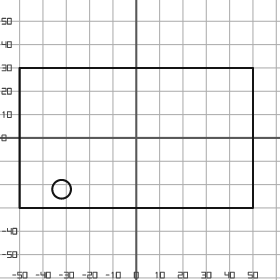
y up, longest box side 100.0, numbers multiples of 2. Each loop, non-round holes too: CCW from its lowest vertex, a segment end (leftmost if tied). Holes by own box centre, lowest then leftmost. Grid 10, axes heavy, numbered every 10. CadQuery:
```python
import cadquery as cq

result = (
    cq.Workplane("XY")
    .moveTo(-50.0, -30.0)
    .lineTo(50.0, -30.0)
    .lineTo(50.0, 30.0)
    .lineTo(-50.0, 30.0)
    .close()
    .moveTo(-32.0, -22.0)
    .circle(4.0)
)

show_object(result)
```